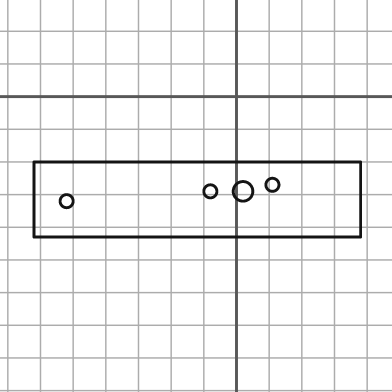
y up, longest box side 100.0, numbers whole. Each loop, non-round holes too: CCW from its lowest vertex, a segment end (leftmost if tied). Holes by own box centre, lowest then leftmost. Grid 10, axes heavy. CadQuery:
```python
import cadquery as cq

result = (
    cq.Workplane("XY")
    .moveTo(-62.0, -43.0)
    .lineTo(38.0, -43.0)
    .lineTo(38.0, -20.0)
    .lineTo(-62.0, -20.0)
    .close()
    .moveTo(-52.0, -32.0)
    .circle(2.0)
    .moveTo(-8.0, -29.0)
    .circle(2.0)
    .moveTo(2.0, -29.0)
    .circle(3.0)
    .moveTo(11.0, -27.0)
    .circle(2.0)
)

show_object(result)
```